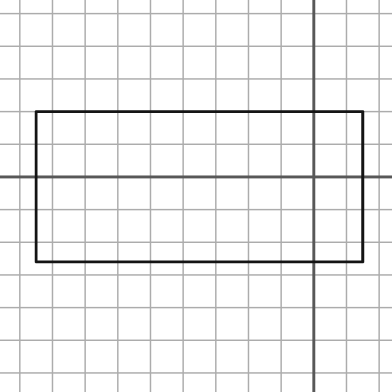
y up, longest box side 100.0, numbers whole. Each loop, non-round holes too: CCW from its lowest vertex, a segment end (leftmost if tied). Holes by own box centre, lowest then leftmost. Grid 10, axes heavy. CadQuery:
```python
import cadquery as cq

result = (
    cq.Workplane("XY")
    .moveTo(-85.0, -26.0)
    .lineTo(15.0, -26.0)
    .lineTo(15.0, 20.0)
    .lineTo(-85.0, 20.0)
    .close()
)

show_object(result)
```